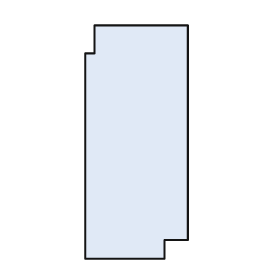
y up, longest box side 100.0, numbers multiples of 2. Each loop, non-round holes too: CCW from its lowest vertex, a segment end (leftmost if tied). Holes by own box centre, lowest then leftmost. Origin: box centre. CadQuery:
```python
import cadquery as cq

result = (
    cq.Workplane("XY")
    .moveTo(-22.0, -50.0)
    .lineTo(12.0, -50.0)
    .lineTo(12.0, -42.0)
    .lineTo(22.0, -42.0)
    .lineTo(22.0, 50.0)
    .lineTo(-18.0, 50.0)
    .lineTo(-18.0, 38.0)
    .lineTo(-22.0, 38.0)
    .close()
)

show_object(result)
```